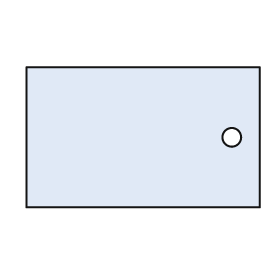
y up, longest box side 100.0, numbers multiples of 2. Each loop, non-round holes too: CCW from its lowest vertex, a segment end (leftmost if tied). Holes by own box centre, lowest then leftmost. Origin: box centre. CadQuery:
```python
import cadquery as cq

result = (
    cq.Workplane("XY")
    .moveTo(-50.0, -30.0)
    .lineTo(50.0, -30.0)
    .lineTo(50.0, 30.0)
    .lineTo(-50.0, 30.0)
    .close()
    .moveTo(38.0, 0.0)
    .circle(4.0)
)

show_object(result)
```